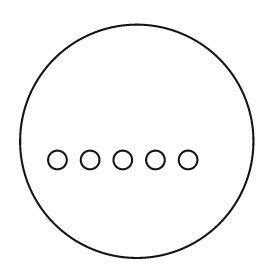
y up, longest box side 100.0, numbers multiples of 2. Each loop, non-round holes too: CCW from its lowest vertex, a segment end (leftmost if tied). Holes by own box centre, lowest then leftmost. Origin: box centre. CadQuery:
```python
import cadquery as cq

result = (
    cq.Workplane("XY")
    .moveTo(0.0, 0.0)
    .circle(50.0)
    .moveTo(-34.0, -8.0)
    .circle(4.0)
    .moveTo(-20.0, -8.0)
    .circle(4.0)
    .moveTo(-6.0, -8.0)
    .circle(4.0)
    .moveTo(8.0, -8.0)
    .circle(4.0)
    .moveTo(22.0, -8.0)
    .circle(4.0)
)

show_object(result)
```